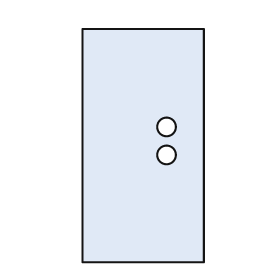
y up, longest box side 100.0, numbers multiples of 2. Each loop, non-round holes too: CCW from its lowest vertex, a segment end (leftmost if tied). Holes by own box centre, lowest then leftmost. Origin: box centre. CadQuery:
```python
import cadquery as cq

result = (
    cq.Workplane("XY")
    .moveTo(-26.0, -50.0)
    .lineTo(26.0, -50.0)
    .lineTo(26.0, 50.0)
    .lineTo(-26.0, 50.0)
    .close()
    .moveTo(10.0, -4.0)
    .circle(4.0)
    .moveTo(10.0, 8.0)
    .circle(4.0)
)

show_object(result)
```